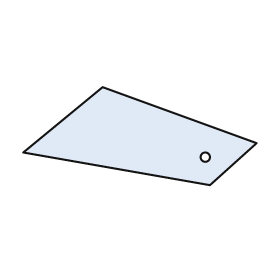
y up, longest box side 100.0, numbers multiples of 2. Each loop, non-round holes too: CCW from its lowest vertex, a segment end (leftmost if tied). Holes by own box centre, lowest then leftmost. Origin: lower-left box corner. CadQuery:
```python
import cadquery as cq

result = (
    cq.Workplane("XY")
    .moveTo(80.0, 0.0)
    .lineTo(100.0, 18.0)
    .lineTo(34.0, 42.0)
    .lineTo(0.0, 14.0)
    .close()
    .moveTo(78.0, 12.0)
    .circle(2.0)
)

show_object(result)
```